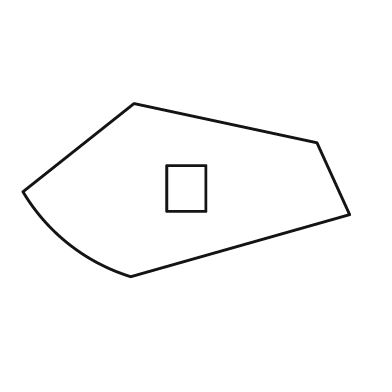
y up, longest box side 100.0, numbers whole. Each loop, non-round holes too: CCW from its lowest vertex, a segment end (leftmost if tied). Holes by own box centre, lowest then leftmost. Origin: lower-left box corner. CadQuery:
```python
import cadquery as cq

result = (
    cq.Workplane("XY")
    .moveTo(33.0, 0.0)
    .lineTo(100.0, 19.0)
    .lineTo(90.0, 41.0)
    .lineTo(34.0, 53.0)
    .lineTo(0.0, 26.0)
    .threePointArc((14.0, 10.0), (33.0, 0.0))
    .close()
    .moveTo(44.0, 20.0)
    .lineTo(56.0, 20.0)
    .lineTo(56.0, 34.0)
    .lineTo(44.0, 34.0)
    .close()
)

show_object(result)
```